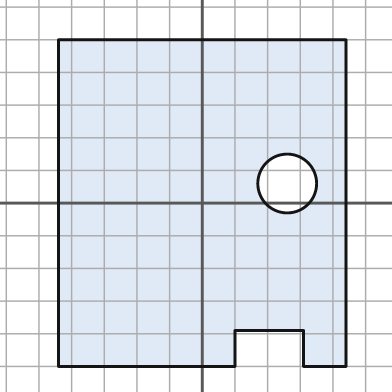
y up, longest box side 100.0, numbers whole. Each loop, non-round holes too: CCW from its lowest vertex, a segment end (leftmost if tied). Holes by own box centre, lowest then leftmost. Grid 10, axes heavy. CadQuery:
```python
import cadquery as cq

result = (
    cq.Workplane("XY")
    .moveTo(-44.0, -50.0)
    .lineTo(10.0, -50.0)
    .lineTo(10.0, -39.0)
    .lineTo(31.0, -39.0)
    .lineTo(31.0, -50.0)
    .lineTo(44.0, -50.0)
    .lineTo(44.0, 50.0)
    .lineTo(-44.0, 50.0)
    .close()
    .moveTo(26.0, 6.0)
    .circle(9.0)
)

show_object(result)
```